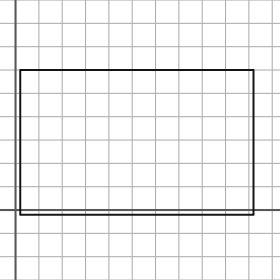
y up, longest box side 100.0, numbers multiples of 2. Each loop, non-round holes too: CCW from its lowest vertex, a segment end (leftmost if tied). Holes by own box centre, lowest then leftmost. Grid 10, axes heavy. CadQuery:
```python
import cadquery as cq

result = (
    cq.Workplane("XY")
    .moveTo(2.0, -2.0)
    .lineTo(102.0, -2.0)
    .lineTo(102.0, 60.0)
    .lineTo(2.0, 60.0)
    .close()
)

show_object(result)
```